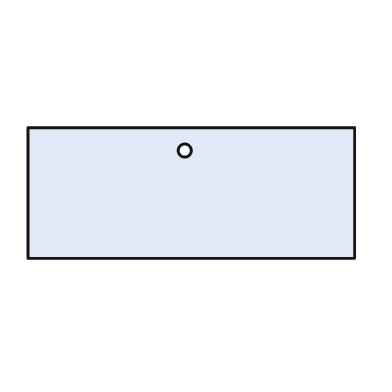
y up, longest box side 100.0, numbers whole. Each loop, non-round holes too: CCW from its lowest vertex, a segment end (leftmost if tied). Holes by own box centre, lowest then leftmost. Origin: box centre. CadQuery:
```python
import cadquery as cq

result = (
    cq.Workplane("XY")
    .moveTo(-50.0, -20.0)
    .lineTo(50.0, -20.0)
    .lineTo(50.0, 20.0)
    .lineTo(-50.0, 20.0)
    .close()
    .moveTo(-2.0, 13.0)
    .circle(2.0)
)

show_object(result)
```